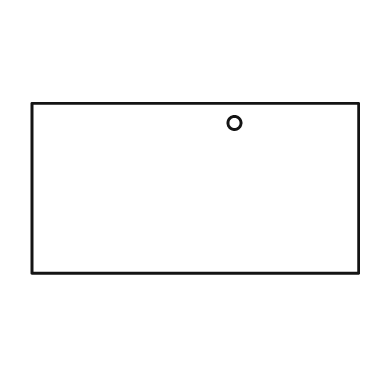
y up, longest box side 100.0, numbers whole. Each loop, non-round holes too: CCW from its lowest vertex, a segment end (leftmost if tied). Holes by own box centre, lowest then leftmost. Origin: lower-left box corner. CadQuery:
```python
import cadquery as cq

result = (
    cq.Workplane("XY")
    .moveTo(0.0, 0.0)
    .lineTo(100.0, 0.0)
    .lineTo(100.0, 52.0)
    .lineTo(0.0, 52.0)
    .close()
    .moveTo(62.0, 46.0)
    .circle(2.0)
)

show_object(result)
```